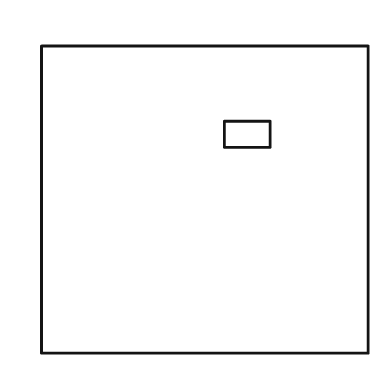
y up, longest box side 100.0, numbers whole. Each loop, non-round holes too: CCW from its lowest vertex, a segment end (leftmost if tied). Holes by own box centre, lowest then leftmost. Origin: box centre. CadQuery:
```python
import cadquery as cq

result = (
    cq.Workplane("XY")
    .moveTo(-50.0, -47.0)
    .lineTo(50.0, -47.0)
    .lineTo(50.0, 47.0)
    .lineTo(-50.0, 47.0)
    .close()
    .moveTo(6.0, 16.0)
    .lineTo(20.0, 16.0)
    .lineTo(20.0, 24.0)
    .lineTo(6.0, 24.0)
    .close()
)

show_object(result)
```